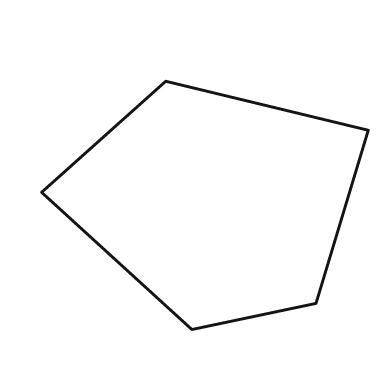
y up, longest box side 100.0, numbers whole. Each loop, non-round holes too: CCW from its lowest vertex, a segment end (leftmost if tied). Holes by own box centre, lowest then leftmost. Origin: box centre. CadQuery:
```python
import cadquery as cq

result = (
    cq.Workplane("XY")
    .moveTo(-4.0, -38.0)
    .lineTo(34.0, -30.0)
    .lineTo(50.0, 23.0)
    .lineTo(-12.0, 38.0)
    .lineTo(-50.0, 4.0)
    .close()
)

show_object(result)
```